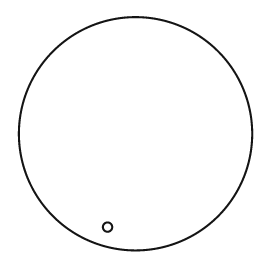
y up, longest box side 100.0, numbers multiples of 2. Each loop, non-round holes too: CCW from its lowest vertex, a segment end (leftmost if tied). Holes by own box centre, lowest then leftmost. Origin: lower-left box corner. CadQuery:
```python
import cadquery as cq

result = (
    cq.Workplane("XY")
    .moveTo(50.0, 50.0)
    .circle(50.0)
    .moveTo(38.0, 10.0)
    .circle(2.0)
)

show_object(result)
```